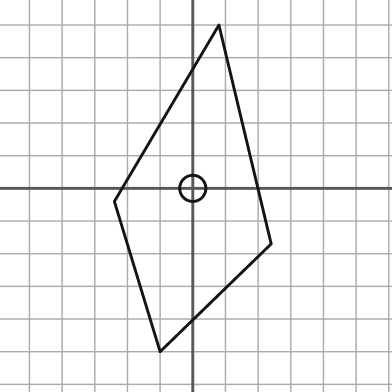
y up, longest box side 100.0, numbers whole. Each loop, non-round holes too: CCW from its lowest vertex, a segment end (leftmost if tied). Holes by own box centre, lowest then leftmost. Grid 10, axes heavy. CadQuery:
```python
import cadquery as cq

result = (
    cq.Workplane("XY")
    .moveTo(-10.0, -50.0)
    .lineTo(24.0, -17.0)
    .lineTo(8.0, 50.0)
    .lineTo(-24.0, -4.0)
    .close()
    .moveTo(0.0, 0.0)
    .circle(4.0)
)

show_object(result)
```